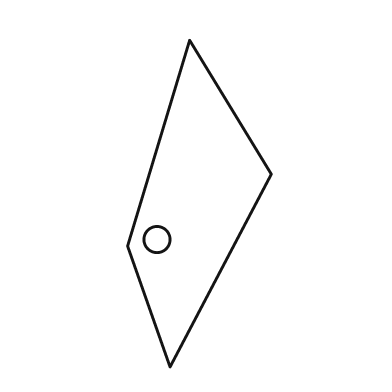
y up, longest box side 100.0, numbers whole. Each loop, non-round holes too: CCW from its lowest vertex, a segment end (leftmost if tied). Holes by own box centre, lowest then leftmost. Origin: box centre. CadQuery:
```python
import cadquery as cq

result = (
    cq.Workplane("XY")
    .moveTo(-9.0, -50.0)
    .lineTo(22.0, 9.0)
    .lineTo(-3.0, 50.0)
    .lineTo(-22.0, -13.0)
    .close()
    .moveTo(-13.0, -11.0)
    .circle(4.0)
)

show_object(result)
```